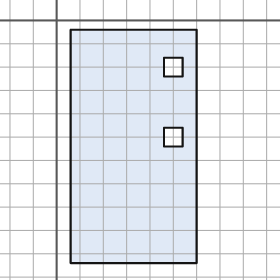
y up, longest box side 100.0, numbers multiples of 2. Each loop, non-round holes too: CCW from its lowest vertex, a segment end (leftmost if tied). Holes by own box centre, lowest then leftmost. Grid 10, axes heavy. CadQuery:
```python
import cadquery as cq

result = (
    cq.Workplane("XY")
    .moveTo(6.0, -104.0)
    .lineTo(60.0, -104.0)
    .lineTo(60.0, -4.0)
    .lineTo(6.0, -4.0)
    .close()
    .moveTo(46.0, -54.0)
    .lineTo(54.0, -54.0)
    .lineTo(54.0, -46.0)
    .lineTo(46.0, -46.0)
    .close()
    .moveTo(46.0, -24.0)
    .lineTo(54.0, -24.0)
    .lineTo(54.0, -16.0)
    .lineTo(46.0, -16.0)
    .close()
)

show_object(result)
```